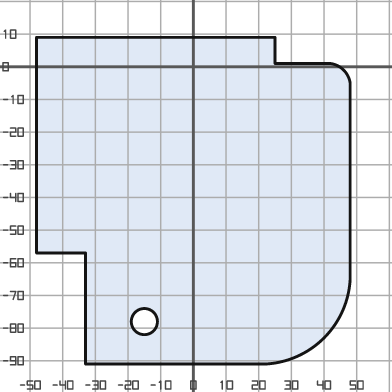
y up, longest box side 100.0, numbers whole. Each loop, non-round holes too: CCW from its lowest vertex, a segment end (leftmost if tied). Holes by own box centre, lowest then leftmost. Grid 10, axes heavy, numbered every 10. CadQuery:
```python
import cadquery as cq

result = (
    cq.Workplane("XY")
    .moveTo(-33.0, -91.0)
    .lineTo(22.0, -91.0)
    .threePointArc((40.0, -83.0), (48.0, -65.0))
    .lineTo(48.0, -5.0)
    .threePointArc((46.0, -1.0), (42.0, 1.0))
    .lineTo(25.0, 1.0)
    .lineTo(25.0, 9.0)
    .lineTo(-48.0, 9.0)
    .lineTo(-48.0, -57.0)
    .lineTo(-33.0, -57.0)
    .close()
    .moveTo(-15.0, -78.0)
    .circle(4.0)
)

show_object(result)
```